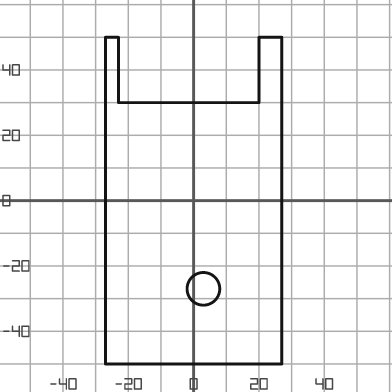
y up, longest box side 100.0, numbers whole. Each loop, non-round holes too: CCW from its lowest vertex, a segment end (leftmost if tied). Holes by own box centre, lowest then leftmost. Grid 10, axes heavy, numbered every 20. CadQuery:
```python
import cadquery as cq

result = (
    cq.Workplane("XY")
    .moveTo(-27.0, -50.0)
    .lineTo(27.0, -50.0)
    .lineTo(27.0, 50.0)
    .lineTo(20.0, 50.0)
    .lineTo(20.0, 30.0)
    .lineTo(-23.0, 30.0)
    .lineTo(-23.0, 50.0)
    .lineTo(-27.0, 50.0)
    .close()
    .moveTo(3.0, -27.0)
    .circle(5.0)
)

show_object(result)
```